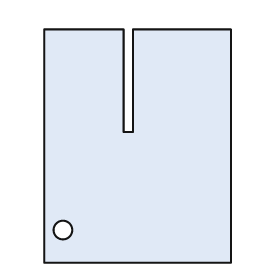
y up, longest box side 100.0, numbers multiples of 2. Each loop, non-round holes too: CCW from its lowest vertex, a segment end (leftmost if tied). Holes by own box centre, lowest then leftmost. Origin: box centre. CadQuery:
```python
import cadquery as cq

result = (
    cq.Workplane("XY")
    .moveTo(-40.0, -50.0)
    .lineTo(40.0, -50.0)
    .lineTo(40.0, 50.0)
    .lineTo(-2.0, 50.0)
    .lineTo(-2.0, 6.0)
    .lineTo(-6.0, 6.0)
    .lineTo(-6.0, 50.0)
    .lineTo(-40.0, 50.0)
    .close()
    .moveTo(-32.0, -36.0)
    .circle(4.0)
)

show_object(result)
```